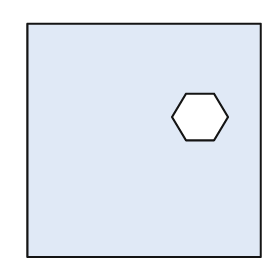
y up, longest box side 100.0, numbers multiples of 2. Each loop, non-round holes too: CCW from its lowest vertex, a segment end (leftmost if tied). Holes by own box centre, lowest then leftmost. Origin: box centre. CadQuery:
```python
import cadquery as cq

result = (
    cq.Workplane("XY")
    .moveTo(-50.0, -50.0)
    .lineTo(50.0, -50.0)
    .lineTo(50.0, 50.0)
    .lineTo(-50.0, 50.0)
    .close()
    .moveTo(18.0, 0.0)
    .lineTo(30.0, 0.0)
    .lineTo(36.0, 10.0)
    .lineTo(30.0, 20.0)
    .lineTo(18.0, 20.0)
    .lineTo(12.0, 10.0)
    .close()
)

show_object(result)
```